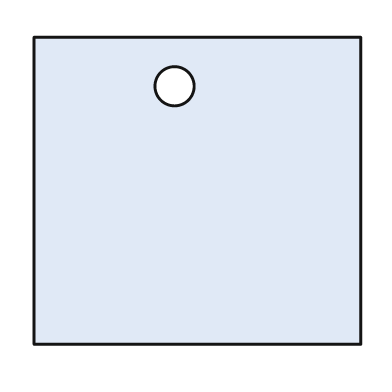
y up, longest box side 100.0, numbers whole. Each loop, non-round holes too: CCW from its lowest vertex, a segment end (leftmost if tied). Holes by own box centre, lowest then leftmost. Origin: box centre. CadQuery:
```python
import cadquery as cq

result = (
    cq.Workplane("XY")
    .moveTo(-50.0, -47.0)
    .lineTo(50.0, -47.0)
    .lineTo(50.0, 47.0)
    .lineTo(-50.0, 47.0)
    .close()
    .moveTo(-7.0, 32.0)
    .circle(6.0)
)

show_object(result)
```